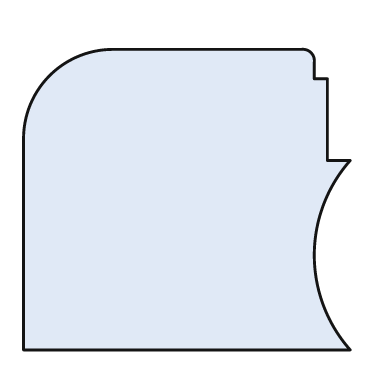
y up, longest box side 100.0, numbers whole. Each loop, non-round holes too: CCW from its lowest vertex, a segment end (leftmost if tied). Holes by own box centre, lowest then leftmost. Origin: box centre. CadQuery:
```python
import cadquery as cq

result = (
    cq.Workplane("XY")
    .moveTo(-50.0, -46.0)
    .lineTo(50.0, -46.0)
    .threePointArc((39.0, -17.0), (50.0, 12.0))
    .lineTo(43.0, 12.0)
    .lineTo(43.0, 37.0)
    .lineTo(39.0, 37.0)
    .lineTo(39.0, 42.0)
    .threePointArc((38.0, 45.0), (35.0, 46.0))
    .lineTo(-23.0, 46.0)
    .threePointArc((-42.0, 38.0), (-50.0, 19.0))
    .close()
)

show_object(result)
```